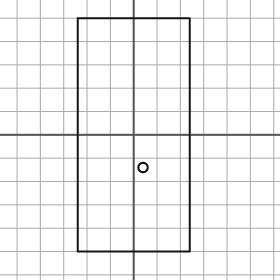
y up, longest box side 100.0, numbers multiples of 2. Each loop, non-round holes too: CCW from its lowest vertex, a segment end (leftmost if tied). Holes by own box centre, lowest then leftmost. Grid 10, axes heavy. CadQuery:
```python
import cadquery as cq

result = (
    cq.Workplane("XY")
    .moveTo(-24.0, -50.0)
    .lineTo(24.0, -50.0)
    .lineTo(24.0, 50.0)
    .lineTo(-24.0, 50.0)
    .close()
    .moveTo(4.0, -14.0)
    .circle(2.0)
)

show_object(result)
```